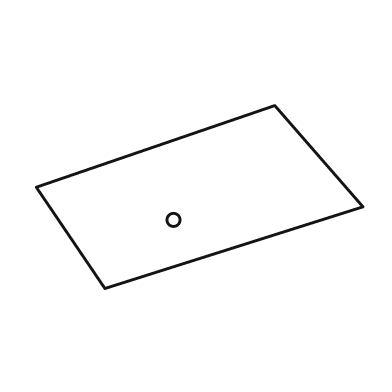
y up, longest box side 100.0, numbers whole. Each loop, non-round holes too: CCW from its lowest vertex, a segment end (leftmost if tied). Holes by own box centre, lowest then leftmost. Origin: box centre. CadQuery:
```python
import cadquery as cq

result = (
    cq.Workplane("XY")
    .moveTo(-29.0, -28.0)
    .lineTo(50.0, -3.0)
    .lineTo(23.0, 28.0)
    .lineTo(-50.0, 3.0)
    .close()
    .moveTo(-8.0, -7.0)
    .circle(2.0)
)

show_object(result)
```